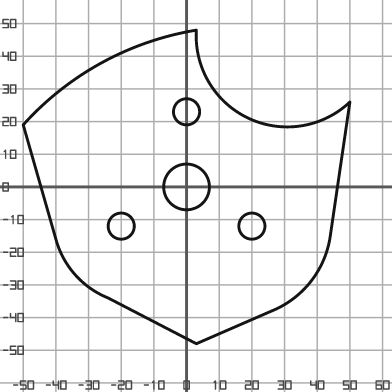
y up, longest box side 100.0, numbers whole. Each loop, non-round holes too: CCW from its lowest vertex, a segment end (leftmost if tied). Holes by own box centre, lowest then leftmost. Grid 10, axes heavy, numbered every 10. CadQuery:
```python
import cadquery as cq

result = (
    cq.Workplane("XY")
    .moveTo(3.0, -48.0)
    .lineTo(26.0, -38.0)
    .threePointArc((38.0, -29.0), (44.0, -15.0))
    .lineTo(50.0, 26.0)
    .threePointArc((19.0, 21.0), (3.0, 48.0))
    .threePointArc((-26.0, 38.0), (-50.0, 19.0))
    .lineTo(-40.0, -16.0)
    .threePointArc((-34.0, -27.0), (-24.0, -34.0))
    .close()
    .moveTo(-20.0, -12.0)
    .circle(4.0)
    .moveTo(20.0, -12.0)
    .circle(4.0)
    .moveTo(0.0, 0.0)
    .circle(7.0)
    .moveTo(0.0, 23.0)
    .circle(4.0)
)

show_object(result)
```